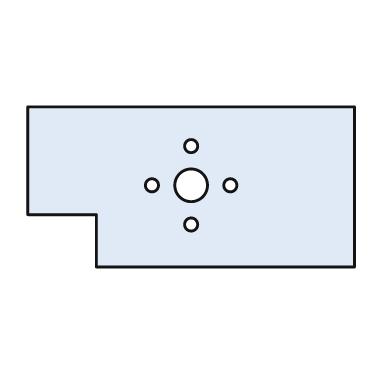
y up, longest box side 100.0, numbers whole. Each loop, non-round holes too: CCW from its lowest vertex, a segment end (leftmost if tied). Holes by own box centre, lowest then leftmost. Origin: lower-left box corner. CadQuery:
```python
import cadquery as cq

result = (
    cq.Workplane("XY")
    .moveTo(21.0, 0.0)
    .lineTo(100.0, 0.0)
    .lineTo(100.0, 49.0)
    .lineTo(0.0, 49.0)
    .lineTo(0.0, 16.0)
    .lineTo(21.0, 16.0)
    .close()
    .moveTo(50.0, 13.0)
    .circle(2.0)
    .moveTo(38.0, 25.0)
    .circle(2.0)
    .moveTo(50.0, 25.0)
    .circle(5.0)
    .moveTo(62.0, 25.0)
    .circle(2.0)
    .moveTo(50.0, 37.0)
    .circle(2.0)
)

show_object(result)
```